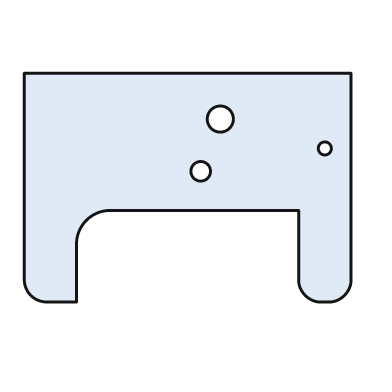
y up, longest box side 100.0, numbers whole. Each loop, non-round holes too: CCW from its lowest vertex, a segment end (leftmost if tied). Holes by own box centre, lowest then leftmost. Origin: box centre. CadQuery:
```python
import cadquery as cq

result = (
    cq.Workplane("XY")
    .moveTo(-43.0, -35.0)
    .lineTo(-34.0, -35.0)
    .lineTo(-34.0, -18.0)
    .threePointArc((-31.0, -10.0), (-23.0, -7.0))
    .lineTo(34.0, -7.0)
    .lineTo(34.0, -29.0)
    .threePointArc((36.0, -33.0), (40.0, -35.0))
    .lineTo(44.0, -35.0)
    .threePointArc((48.0, -33.0), (50.0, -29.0))
    .lineTo(50.0, 35.0)
    .lineTo(-50.0, 35.0)
    .lineTo(-50.0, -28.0)
    .threePointArc((-48.0, -33.0), (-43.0, -35.0))
    .close()
    .moveTo(4.0, 5.0)
    .circle(3.0)
    .moveTo(42.0, 12.0)
    .circle(2.0)
    .moveTo(10.0, 21.0)
    .circle(4.0)
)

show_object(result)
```